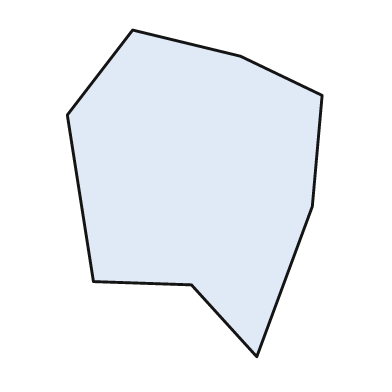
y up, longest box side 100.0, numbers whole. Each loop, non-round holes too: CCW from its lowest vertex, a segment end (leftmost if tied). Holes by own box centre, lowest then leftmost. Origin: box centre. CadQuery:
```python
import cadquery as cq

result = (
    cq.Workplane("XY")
    .moveTo(19.0, -50.0)
    .lineTo(36.0, -4.0)
    .lineTo(39.0, 30.0)
    .lineTo(14.0, 42.0)
    .lineTo(-19.0, 50.0)
    .lineTo(-39.0, 24.0)
    .lineTo(-31.0, -27.0)
    .lineTo(-1.0, -28.0)
    .close()
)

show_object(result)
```